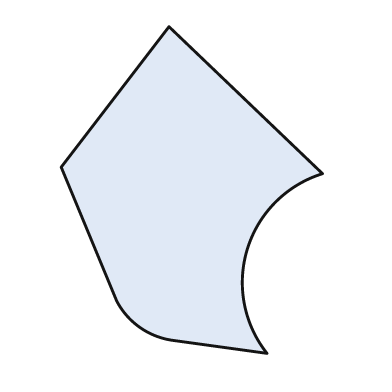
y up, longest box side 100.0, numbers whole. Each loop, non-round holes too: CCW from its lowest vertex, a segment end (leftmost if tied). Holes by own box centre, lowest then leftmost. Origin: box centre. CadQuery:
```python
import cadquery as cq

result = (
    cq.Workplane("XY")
    .moveTo(23.0, -50.0)
    .threePointArc((17.0, -18.0), (40.0, 5.0))
    .lineTo(-7.0, 50.0)
    .lineTo(-40.0, 7.0)
    .lineTo(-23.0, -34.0)
    .threePointArc((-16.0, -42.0), (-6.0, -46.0))
    .close()
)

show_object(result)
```